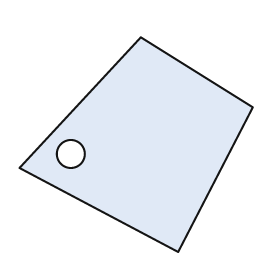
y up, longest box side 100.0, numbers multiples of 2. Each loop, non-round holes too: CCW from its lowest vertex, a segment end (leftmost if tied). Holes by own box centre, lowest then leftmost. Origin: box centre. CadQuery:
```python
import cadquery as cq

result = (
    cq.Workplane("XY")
    .moveTo(18.0, -46.0)
    .lineTo(50.0, 16.0)
    .lineTo(2.0, 46.0)
    .lineTo(-50.0, -10.0)
    .close()
    .moveTo(-28.0, -4.0)
    .circle(6.0)
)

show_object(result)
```